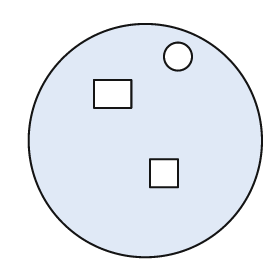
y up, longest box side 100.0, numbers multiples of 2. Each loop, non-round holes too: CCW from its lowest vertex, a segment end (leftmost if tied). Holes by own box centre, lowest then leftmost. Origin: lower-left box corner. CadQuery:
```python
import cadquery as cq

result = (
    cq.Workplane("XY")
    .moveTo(50.0, 50.0)
    .circle(50.0)
    .moveTo(52.0, 30.0)
    .lineTo(64.0, 30.0)
    .lineTo(64.0, 42.0)
    .lineTo(52.0, 42.0)
    .close()
    .moveTo(28.0, 64.0)
    .lineTo(44.0, 64.0)
    .lineTo(44.0, 76.0)
    .lineTo(28.0, 76.0)
    .close()
    .moveTo(64.0, 86.0)
    .circle(6.0)
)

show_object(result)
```